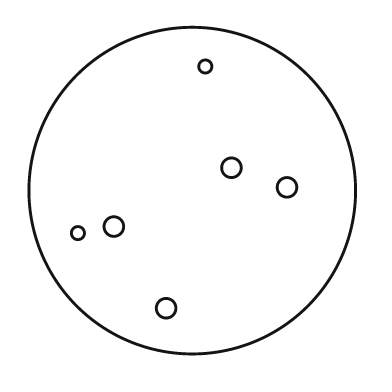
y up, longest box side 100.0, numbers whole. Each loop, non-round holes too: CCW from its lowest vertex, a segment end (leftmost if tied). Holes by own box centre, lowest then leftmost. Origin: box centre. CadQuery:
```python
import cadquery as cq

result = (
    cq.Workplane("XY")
    .moveTo(0.0, 0.0)
    .circle(50.0)
    .moveTo(-8.0, -36.0)
    .circle(3.0)
    .moveTo(-35.0, -13.0)
    .circle(2.0)
    .moveTo(-24.0, -11.0)
    .circle(3.0)
    .moveTo(29.0, 1.0)
    .circle(3.0)
    .moveTo(12.0, 7.0)
    .circle(3.0)
    .moveTo(4.0, 38.0)
    .circle(2.0)
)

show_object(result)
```